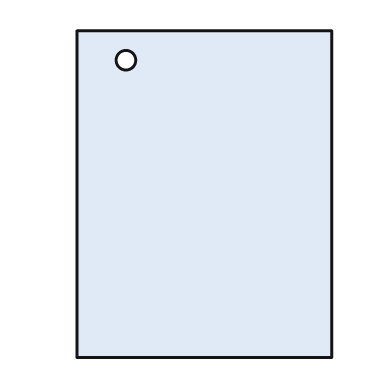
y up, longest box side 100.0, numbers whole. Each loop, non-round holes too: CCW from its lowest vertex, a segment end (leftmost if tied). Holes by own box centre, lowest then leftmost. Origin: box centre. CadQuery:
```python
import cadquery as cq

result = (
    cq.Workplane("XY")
    .moveTo(-39.0, -50.0)
    .lineTo(39.0, -50.0)
    .lineTo(39.0, 50.0)
    .lineTo(-39.0, 50.0)
    .close()
    .moveTo(-24.0, 41.0)
    .circle(3.0)
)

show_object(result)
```